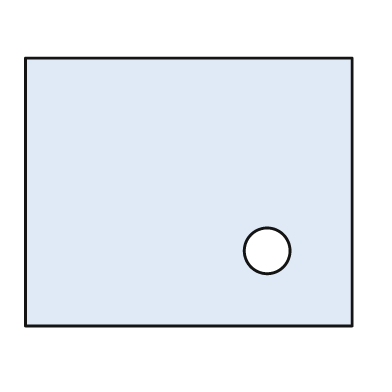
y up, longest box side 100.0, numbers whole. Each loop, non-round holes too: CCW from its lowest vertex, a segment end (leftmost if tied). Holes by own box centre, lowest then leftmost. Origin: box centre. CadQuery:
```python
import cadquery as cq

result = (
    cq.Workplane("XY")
    .moveTo(-50.0, -41.0)
    .lineTo(50.0, -41.0)
    .lineTo(50.0, 41.0)
    .lineTo(-50.0, 41.0)
    .close()
    .moveTo(24.0, -18.0)
    .circle(7.0)
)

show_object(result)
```